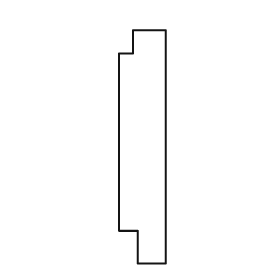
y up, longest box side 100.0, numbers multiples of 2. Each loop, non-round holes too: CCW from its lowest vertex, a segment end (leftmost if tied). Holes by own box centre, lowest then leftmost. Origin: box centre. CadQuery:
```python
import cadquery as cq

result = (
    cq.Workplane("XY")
    .moveTo(-2.0, -50.0)
    .lineTo(10.0, -50.0)
    .lineTo(10.0, 50.0)
    .lineTo(-4.0, 50.0)
    .lineTo(-4.0, 40.0)
    .lineTo(-10.0, 40.0)
    .lineTo(-10.0, -36.0)
    .lineTo(-2.0, -36.0)
    .close()
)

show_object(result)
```